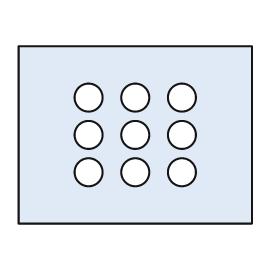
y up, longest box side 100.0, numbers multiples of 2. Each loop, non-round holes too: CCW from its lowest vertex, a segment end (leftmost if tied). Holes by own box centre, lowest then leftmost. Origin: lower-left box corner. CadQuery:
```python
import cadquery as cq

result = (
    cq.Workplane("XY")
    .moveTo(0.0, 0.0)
    .lineTo(100.0, 0.0)
    .lineTo(100.0, 76.0)
    .lineTo(0.0, 76.0)
    .close()
    .moveTo(30.0, 22.0)
    .circle(6.0)
    .moveTo(50.0, 22.0)
    .circle(6.0)
    .moveTo(70.0, 22.0)
    .circle(6.0)
    .moveTo(30.0, 38.0)
    .circle(6.0)
    .moveTo(50.0, 38.0)
    .circle(6.0)
    .moveTo(70.0, 38.0)
    .circle(6.0)
    .moveTo(30.0, 54.0)
    .circle(6.0)
    .moveTo(50.0, 54.0)
    .circle(6.0)
    .moveTo(70.0, 54.0)
    .circle(6.0)
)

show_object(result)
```